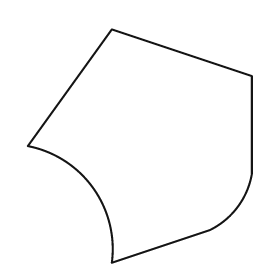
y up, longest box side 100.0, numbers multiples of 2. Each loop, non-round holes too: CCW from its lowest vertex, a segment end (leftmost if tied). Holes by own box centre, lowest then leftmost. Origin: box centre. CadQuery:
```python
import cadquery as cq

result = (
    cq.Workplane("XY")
    .moveTo(-12.0, -50.0)
    .lineTo(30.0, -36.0)
    .threePointArc((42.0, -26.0), (48.0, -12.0))
    .lineTo(48.0, 30.0)
    .lineTo(-12.0, 50.0)
    .lineTo(-48.0, 0.0)
    .threePointArc((-20.0, -18.0), (-12.0, -50.0))
    .close()
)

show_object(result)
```